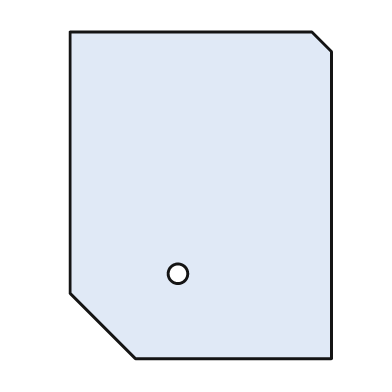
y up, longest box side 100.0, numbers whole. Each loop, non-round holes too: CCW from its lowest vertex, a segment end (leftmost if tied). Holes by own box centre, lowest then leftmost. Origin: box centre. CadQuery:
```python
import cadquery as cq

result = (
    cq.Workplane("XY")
    .moveTo(-20.0, -50.0)
    .lineTo(40.0, -50.0)
    .lineTo(40.0, 44.0)
    .lineTo(34.0, 50.0)
    .lineTo(-40.0, 50.0)
    .lineTo(-40.0, -30.0)
    .close()
    .moveTo(-7.0, -24.0)
    .circle(3.0)
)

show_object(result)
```